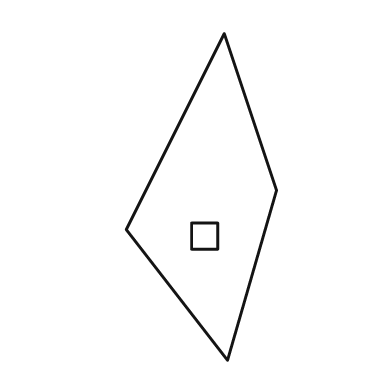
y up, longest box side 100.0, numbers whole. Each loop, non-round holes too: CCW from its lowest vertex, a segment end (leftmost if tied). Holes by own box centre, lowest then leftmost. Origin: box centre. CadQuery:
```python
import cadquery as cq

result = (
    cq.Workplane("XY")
    .moveTo(8.0, -50.0)
    .lineTo(23.0, 2.0)
    .lineTo(7.0, 50.0)
    .lineTo(-23.0, -10.0)
    .close()
    .moveTo(-3.0, -16.0)
    .lineTo(5.0, -16.0)
    .lineTo(5.0, -8.0)
    .lineTo(-3.0, -8.0)
    .close()
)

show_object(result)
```